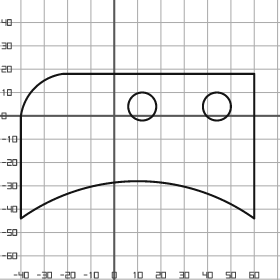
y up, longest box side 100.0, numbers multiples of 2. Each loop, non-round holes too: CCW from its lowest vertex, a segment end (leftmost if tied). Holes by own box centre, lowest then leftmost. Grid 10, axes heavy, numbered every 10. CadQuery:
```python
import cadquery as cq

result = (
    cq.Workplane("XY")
    .moveTo(-40.0, -44.0)
    .threePointArc((10.0, -28.0), (60.0, -44.0))
    .lineTo(60.0, 18.0)
    .lineTo(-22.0, 18.0)
    .threePointArc((-34.0, 12.0), (-40.0, 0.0))
    .close()
    .moveTo(12.0, 4.0)
    .circle(6.0)
    .moveTo(44.0, 4.0)
    .circle(6.0)
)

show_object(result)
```